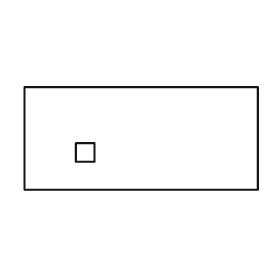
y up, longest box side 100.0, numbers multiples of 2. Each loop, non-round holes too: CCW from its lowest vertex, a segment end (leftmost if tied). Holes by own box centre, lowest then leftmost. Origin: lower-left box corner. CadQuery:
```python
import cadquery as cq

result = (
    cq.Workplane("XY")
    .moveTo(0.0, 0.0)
    .lineTo(100.0, 0.0)
    .lineTo(100.0, 44.0)
    .lineTo(0.0, 44.0)
    .close()
    .moveTo(22.0, 12.0)
    .lineTo(30.0, 12.0)
    .lineTo(30.0, 20.0)
    .lineTo(22.0, 20.0)
    .close()
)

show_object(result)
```